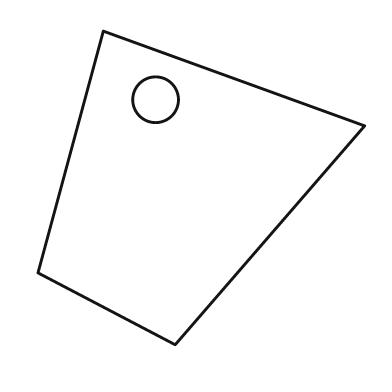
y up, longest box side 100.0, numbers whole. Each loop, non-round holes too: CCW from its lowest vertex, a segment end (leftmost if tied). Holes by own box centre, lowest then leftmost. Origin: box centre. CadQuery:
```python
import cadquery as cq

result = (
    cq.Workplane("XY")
    .moveTo(-8.0, -48.0)
    .lineTo(50.0, 19.0)
    .lineTo(-30.0, 48.0)
    .lineTo(-50.0, -26.0)
    .close()
    .moveTo(-14.0, 27.0)
    .circle(7.0)
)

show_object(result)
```